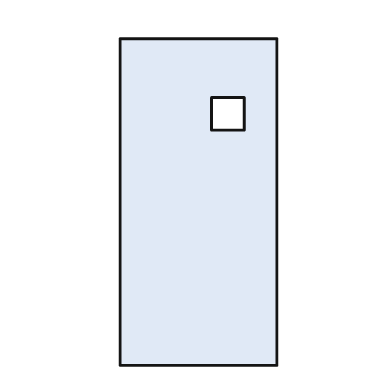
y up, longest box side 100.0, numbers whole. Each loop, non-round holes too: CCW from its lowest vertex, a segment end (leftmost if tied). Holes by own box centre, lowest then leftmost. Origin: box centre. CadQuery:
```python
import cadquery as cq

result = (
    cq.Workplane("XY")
    .moveTo(-24.0, -50.0)
    .lineTo(24.0, -50.0)
    .lineTo(24.0, 50.0)
    .lineTo(-24.0, 50.0)
    .close()
    .moveTo(4.0, 22.0)
    .lineTo(14.0, 22.0)
    .lineTo(14.0, 32.0)
    .lineTo(4.0, 32.0)
    .close()
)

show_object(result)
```